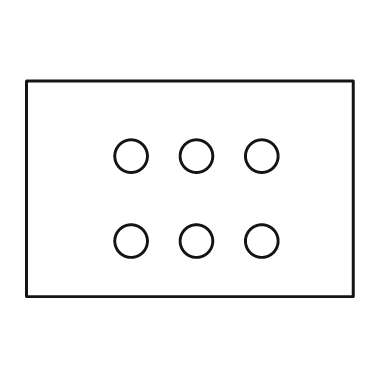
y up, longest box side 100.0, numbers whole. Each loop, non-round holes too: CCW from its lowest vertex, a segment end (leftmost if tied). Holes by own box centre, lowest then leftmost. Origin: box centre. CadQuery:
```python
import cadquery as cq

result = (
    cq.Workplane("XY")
    .moveTo(-50.0, -33.0)
    .lineTo(50.0, -33.0)
    .lineTo(50.0, 33.0)
    .lineTo(-50.0, 33.0)
    .close()
    .moveTo(-18.0, -16.0)
    .circle(5.0)
    .moveTo(2.0, -16.0)
    .circle(5.0)
    .moveTo(22.0, -16.0)
    .circle(5.0)
    .moveTo(-18.0, 10.0)
    .circle(5.0)
    .moveTo(2.0, 10.0)
    .circle(5.0)
    .moveTo(22.0, 10.0)
    .circle(5.0)
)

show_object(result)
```